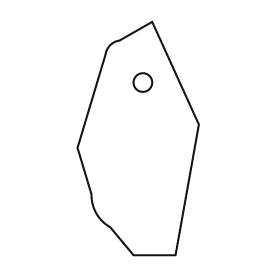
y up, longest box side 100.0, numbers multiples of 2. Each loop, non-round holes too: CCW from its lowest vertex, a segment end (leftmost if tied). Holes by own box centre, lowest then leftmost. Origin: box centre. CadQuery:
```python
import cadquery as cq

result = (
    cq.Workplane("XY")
    .moveTo(-2.0, -50.0)
    .lineTo(16.0, -50.0)
    .lineTo(26.0, 6.0)
    .lineTo(6.0, 50.0)
    .lineTo(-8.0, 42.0)
    .threePointArc((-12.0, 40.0), (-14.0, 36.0))
    .lineTo(-26.0, -4.0)
    .lineTo(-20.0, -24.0)
    .threePointArc((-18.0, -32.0), (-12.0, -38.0))
    .close()
    .moveTo(2.0, 24.0)
    .circle(4.0)
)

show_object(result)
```